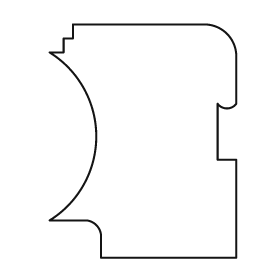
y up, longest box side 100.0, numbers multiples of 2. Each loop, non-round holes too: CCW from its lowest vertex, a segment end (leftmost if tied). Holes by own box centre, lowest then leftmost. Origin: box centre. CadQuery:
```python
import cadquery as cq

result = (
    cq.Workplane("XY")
    .moveTo(-18.0, -50.0)
    .lineTo(40.0, -50.0)
    .lineTo(40.0, -8.0)
    .lineTo(32.0, -8.0)
    .lineTo(32.0, 16.0)
    .threePointArc((36.0, 14.0), (40.0, 16.0))
    .lineTo(40.0, 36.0)
    .threePointArc((36.0, 46.0), (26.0, 50.0))
    .lineTo(-30.0, 50.0)
    .lineTo(-30.0, 44.0)
    .lineTo(-34.0, 44.0)
    .lineTo(-34.0, 38.0)
    .lineTo(-40.0, 38.0)
    .threePointArc((-20.0, 2.0), (-40.0, -34.0))
    .lineTo(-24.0, -34.0)
    .threePointArc((-20.0, -36.0), (-18.0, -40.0))
    .close()
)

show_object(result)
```